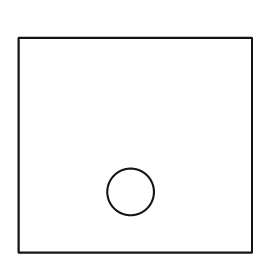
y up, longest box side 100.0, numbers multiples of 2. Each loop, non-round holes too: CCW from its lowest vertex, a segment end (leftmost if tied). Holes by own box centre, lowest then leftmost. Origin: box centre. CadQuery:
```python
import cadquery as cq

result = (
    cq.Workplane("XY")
    .moveTo(-50.0, -46.0)
    .lineTo(50.0, -46.0)
    .lineTo(50.0, 46.0)
    .lineTo(-50.0, 46.0)
    .close()
    .moveTo(-2.0, -20.0)
    .circle(10.0)
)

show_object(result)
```